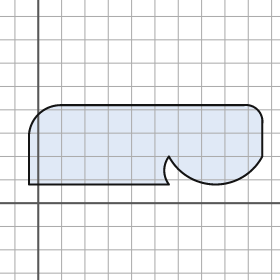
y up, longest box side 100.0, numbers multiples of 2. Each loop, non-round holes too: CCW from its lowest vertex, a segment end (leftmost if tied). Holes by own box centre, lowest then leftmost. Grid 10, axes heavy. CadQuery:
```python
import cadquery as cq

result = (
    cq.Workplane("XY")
    .moveTo(-4.0, 8.0)
    .lineTo(56.0, 8.0)
    .threePointArc((54.0, 14.0), (56.0, 20.0))
    .threePointArc((76.0, 8.0), (96.0, 20.0))
    .lineTo(96.0, 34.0)
    .threePointArc((94.0, 40.0), (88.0, 42.0))
    .lineTo(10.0, 42.0)
    .threePointArc((0.0, 38.0), (-4.0, 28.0))
    .close()
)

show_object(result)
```